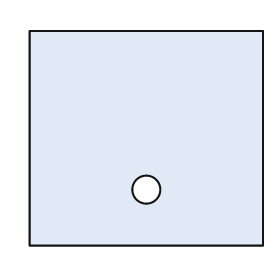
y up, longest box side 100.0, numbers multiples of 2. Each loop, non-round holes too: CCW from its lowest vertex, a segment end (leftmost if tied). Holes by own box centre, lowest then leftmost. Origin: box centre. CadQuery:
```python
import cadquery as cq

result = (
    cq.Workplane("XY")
    .moveTo(-50.0, -46.0)
    .lineTo(50.0, -46.0)
    .lineTo(50.0, 46.0)
    .lineTo(-50.0, 46.0)
    .close()
    .moveTo(0.0, -22.0)
    .circle(6.0)
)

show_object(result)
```